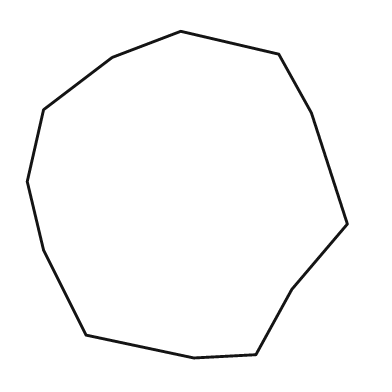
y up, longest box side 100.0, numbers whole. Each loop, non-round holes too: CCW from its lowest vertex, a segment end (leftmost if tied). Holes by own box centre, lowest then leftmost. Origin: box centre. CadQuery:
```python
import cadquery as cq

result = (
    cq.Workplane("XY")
    .moveTo(2.0, -50.0)
    .lineTo(21.0, -49.0)
    .lineTo(32.0, -29.0)
    .lineTo(49.0, -9.0)
    .lineTo(38.0, 25.0)
    .lineTo(28.0, 43.0)
    .lineTo(-2.0, 50.0)
    .lineTo(-23.0, 42.0)
    .lineTo(-44.0, 26.0)
    .lineTo(-49.0, 4.0)
    .lineTo(-44.0, -17.0)
    .lineTo(-31.0, -43.0)
    .close()
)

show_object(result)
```